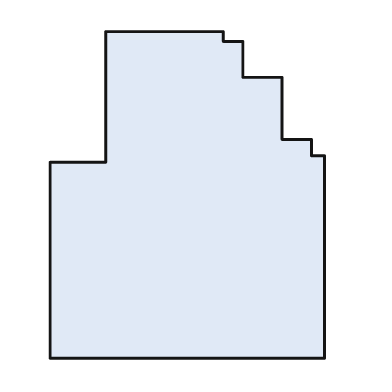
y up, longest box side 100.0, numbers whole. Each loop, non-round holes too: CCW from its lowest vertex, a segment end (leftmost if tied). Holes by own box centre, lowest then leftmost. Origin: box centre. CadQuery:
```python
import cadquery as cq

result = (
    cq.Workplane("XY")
    .moveTo(-42.0, -50.0)
    .lineTo(42.0, -50.0)
    .lineTo(42.0, 12.0)
    .lineTo(38.0, 12.0)
    .lineTo(38.0, 17.0)
    .lineTo(29.0, 17.0)
    .lineTo(29.0, 36.0)
    .lineTo(17.0, 36.0)
    .lineTo(17.0, 47.0)
    .lineTo(11.0, 47.0)
    .lineTo(11.0, 50.0)
    .lineTo(-25.0, 50.0)
    .lineTo(-25.0, 10.0)
    .lineTo(-42.0, 10.0)
    .close()
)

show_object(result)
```